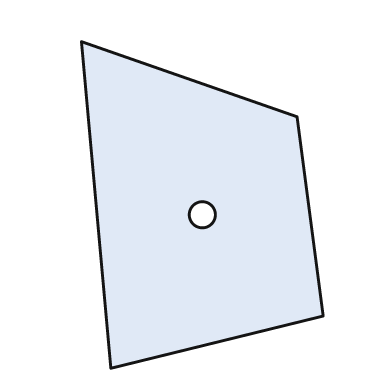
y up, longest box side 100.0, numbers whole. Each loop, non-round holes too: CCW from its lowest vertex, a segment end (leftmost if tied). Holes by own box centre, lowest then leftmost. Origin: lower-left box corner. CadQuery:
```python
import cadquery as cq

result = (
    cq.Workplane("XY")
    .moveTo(9.0, 0.0)
    .lineTo(74.0, 16.0)
    .lineTo(66.0, 77.0)
    .lineTo(0.0, 100.0)
    .close()
    .moveTo(37.0, 47.0)
    .circle(4.0)
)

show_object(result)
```